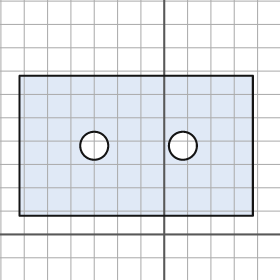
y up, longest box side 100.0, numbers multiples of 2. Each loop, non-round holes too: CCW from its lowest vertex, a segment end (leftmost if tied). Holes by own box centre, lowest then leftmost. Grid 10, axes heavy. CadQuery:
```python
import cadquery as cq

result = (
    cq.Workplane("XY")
    .moveTo(-62.0, 8.0)
    .lineTo(38.0, 8.0)
    .lineTo(38.0, 68.0)
    .lineTo(-62.0, 68.0)
    .close()
    .moveTo(-30.0, 38.0)
    .circle(6.0)
    .moveTo(8.0, 38.0)
    .circle(6.0)
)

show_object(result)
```